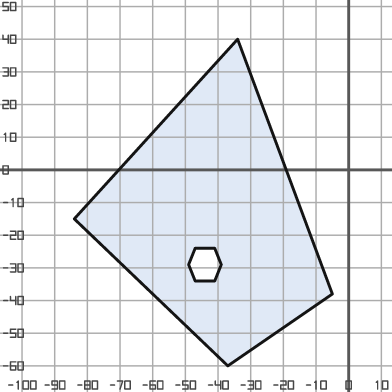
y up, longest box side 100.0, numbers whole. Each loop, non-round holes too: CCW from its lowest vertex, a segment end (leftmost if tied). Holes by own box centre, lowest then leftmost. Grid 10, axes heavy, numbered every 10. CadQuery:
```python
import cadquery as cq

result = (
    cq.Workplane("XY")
    .moveTo(-37.0, -60.0)
    .lineTo(-5.0, -38.0)
    .lineTo(-34.0, 40.0)
    .lineTo(-84.0, -15.0)
    .close()
    .moveTo(-47.0, -34.0)
    .lineTo(-41.0, -34.0)
    .lineTo(-39.0, -29.0)
    .lineTo(-41.0, -24.0)
    .lineTo(-47.0, -24.0)
    .lineTo(-49.0, -29.0)
    .close()
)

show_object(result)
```